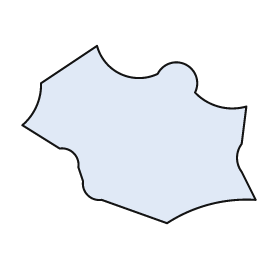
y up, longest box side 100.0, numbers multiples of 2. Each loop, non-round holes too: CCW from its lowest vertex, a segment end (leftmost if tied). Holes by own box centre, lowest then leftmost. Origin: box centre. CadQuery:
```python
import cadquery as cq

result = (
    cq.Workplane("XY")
    .moveTo(12.0, -38.0)
    .threePointArc((30.0, -30.0), (50.0, -28.0))
    .lineTo(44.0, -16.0)
    .threePointArc((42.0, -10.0), (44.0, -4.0))
    .lineTo(46.0, 12.0)
    .threePointArc((34.0, 12.0), (24.0, 18.0))
    .threePointArc((20.0, 30.0), (8.0, 26.0))
    .threePointArc((-8.0, 26.0), (-18.0, 38.0))
    .lineTo(-42.0, 22.0)
    .threePointArc((-44.0, 12.0), (-50.0, 4.0))
    .lineTo(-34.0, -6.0)
    .threePointArc((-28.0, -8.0), (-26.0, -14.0))
    .lineTo(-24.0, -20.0)
    .threePointArc((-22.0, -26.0), (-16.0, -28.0))
    .close()
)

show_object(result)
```